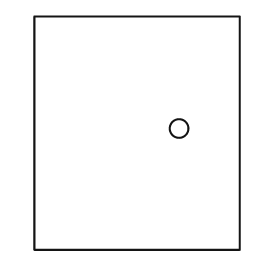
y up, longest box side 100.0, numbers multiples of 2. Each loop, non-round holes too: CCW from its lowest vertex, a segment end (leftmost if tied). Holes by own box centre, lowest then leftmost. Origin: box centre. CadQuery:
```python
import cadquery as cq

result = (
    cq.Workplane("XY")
    .moveTo(-44.0, -50.0)
    .lineTo(44.0, -50.0)
    .lineTo(44.0, 50.0)
    .lineTo(-44.0, 50.0)
    .close()
    .moveTo(18.0, 2.0)
    .circle(4.0)
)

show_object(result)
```